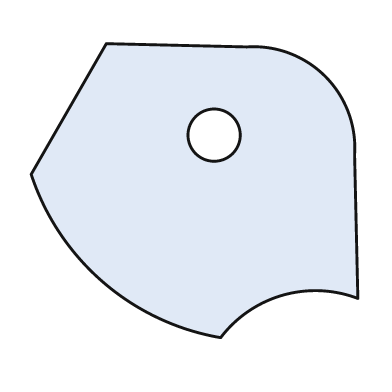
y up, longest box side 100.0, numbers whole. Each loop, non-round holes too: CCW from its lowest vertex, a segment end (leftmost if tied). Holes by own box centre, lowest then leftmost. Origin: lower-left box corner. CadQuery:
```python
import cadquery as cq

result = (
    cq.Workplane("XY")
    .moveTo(58.0, 0.0)
    .threePointArc((77.0, 13.0), (100.0, 12.0))
    .lineTo(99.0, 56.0)
    .threePointArc((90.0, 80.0), (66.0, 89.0))
    .lineTo(23.0, 90.0)
    .lineTo(0.0, 50.0)
    .threePointArc((22.0, 17.0), (58.0, 0.0))
    .close()
    .moveTo(56.0, 62.0)
    .circle(8.0)
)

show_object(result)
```